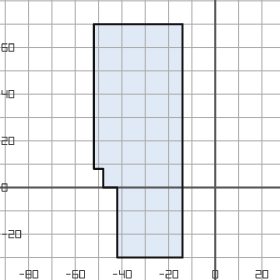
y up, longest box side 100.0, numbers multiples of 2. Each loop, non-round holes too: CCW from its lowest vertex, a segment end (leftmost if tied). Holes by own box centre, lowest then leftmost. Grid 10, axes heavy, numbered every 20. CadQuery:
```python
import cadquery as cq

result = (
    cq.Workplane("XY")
    .moveTo(-42.0, -30.0)
    .lineTo(-14.0, -30.0)
    .lineTo(-14.0, 70.0)
    .lineTo(-52.0, 70.0)
    .lineTo(-52.0, 8.0)
    .lineTo(-48.0, 8.0)
    .lineTo(-48.0, 0.0)
    .lineTo(-42.0, 0.0)
    .close()
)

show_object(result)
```